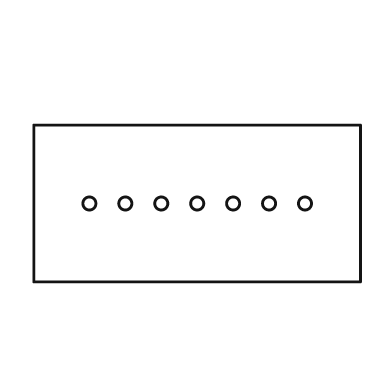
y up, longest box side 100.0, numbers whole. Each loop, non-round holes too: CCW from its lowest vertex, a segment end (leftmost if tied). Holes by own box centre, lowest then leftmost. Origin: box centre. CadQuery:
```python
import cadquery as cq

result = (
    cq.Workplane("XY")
    .moveTo(-50.0, -24.0)
    .lineTo(50.0, -24.0)
    .lineTo(50.0, 24.0)
    .lineTo(-50.0, 24.0)
    .close()
    .moveTo(-33.0, 0.0)
    .circle(2.0)
    .moveTo(-22.0, 0.0)
    .circle(2.0)
    .moveTo(-11.0, 0.0)
    .circle(2.0)
    .moveTo(0.0, 0.0)
    .circle(2.0)
    .moveTo(11.0, 0.0)
    .circle(2.0)
    .moveTo(22.0, 0.0)
    .circle(2.0)
    .moveTo(33.0, 0.0)
    .circle(2.0)
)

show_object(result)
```